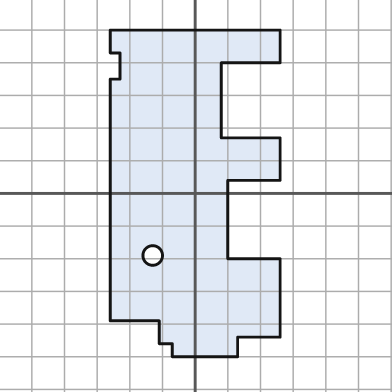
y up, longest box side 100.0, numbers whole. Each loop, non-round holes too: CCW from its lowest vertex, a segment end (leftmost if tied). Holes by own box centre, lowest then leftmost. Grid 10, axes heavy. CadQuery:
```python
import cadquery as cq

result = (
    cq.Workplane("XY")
    .moveTo(-7.0, -50.0)
    .lineTo(13.0, -50.0)
    .lineTo(13.0, -44.0)
    .lineTo(26.0, -44.0)
    .lineTo(26.0, -20.0)
    .lineTo(10.0, -20.0)
    .lineTo(10.0, 4.0)
    .lineTo(26.0, 4.0)
    .lineTo(26.0, 17.0)
    .lineTo(8.0, 17.0)
    .lineTo(8.0, 40.0)
    .lineTo(26.0, 40.0)
    .lineTo(26.0, 50.0)
    .lineTo(-26.0, 50.0)
    .lineTo(-26.0, 43.0)
    .lineTo(-23.0, 43.0)
    .lineTo(-23.0, 35.0)
    .lineTo(-26.0, 35.0)
    .lineTo(-26.0, -39.0)
    .lineTo(-11.0, -39.0)
    .lineTo(-11.0, -46.0)
    .lineTo(-7.0, -46.0)
    .close()
    .moveTo(-13.0, -19.0)
    .circle(3.0)
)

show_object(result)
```